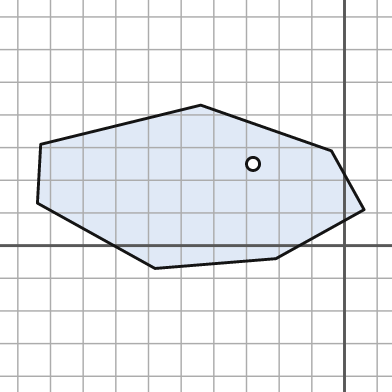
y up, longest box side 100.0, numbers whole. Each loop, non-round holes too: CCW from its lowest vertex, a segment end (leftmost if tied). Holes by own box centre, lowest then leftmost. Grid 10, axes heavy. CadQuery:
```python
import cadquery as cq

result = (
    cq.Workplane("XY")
    .moveTo(-58.0, -7.0)
    .lineTo(-21.0, -4.0)
    .lineTo(6.0, 11.0)
    .lineTo(-4.0, 29.0)
    .lineTo(-44.0, 43.0)
    .lineTo(-93.0, 31.0)
    .lineTo(-94.0, 13.0)
    .close()
    .moveTo(-28.0, 25.0)
    .circle(2.0)
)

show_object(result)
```